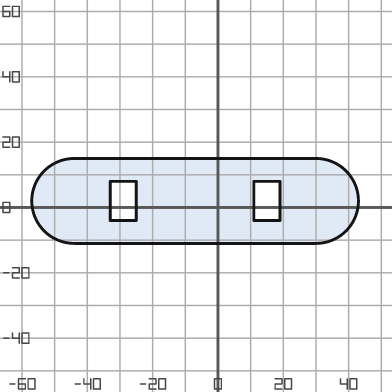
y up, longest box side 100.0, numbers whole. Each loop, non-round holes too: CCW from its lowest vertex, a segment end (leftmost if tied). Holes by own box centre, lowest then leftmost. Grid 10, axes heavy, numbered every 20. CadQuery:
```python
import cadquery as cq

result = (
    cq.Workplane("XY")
    .moveTo(-44.0, -11.0)
    .lineTo(30.0, -11.0)
    .threePointArc((43.0, 2.0), (30.0, 15.0))
    .lineTo(-44.0, 15.0)
    .threePointArc((-57.0, 2.0), (-44.0, -11.0))
    .close()
    .moveTo(-33.0, -4.0)
    .lineTo(-25.0, -4.0)
    .lineTo(-25.0, 8.0)
    .lineTo(-33.0, 8.0)
    .close()
    .moveTo(11.0, -4.0)
    .lineTo(19.0, -4.0)
    .lineTo(19.0, 8.0)
    .lineTo(11.0, 8.0)
    .close()
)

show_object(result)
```